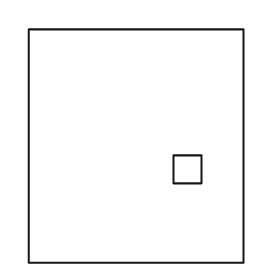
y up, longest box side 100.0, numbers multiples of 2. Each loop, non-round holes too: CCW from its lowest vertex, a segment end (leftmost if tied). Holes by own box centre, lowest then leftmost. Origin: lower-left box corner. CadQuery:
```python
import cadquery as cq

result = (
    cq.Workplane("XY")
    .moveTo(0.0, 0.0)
    .lineTo(92.0, 0.0)
    .lineTo(92.0, 100.0)
    .lineTo(0.0, 100.0)
    .close()
    .moveTo(62.0, 34.0)
    .lineTo(74.0, 34.0)
    .lineTo(74.0, 46.0)
    .lineTo(62.0, 46.0)
    .close()
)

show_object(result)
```